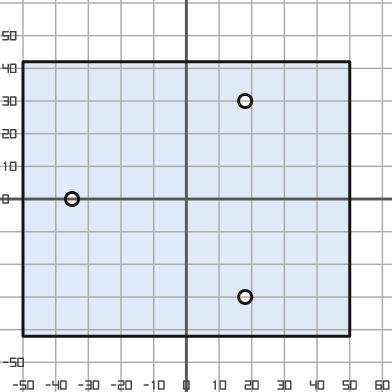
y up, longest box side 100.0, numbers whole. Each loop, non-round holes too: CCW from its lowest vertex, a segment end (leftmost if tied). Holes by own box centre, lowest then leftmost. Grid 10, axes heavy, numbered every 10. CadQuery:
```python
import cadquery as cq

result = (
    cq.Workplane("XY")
    .moveTo(-50.0, -42.0)
    .lineTo(50.0, -42.0)
    .lineTo(50.0, 42.0)
    .lineTo(-50.0, 42.0)
    .close()
    .moveTo(18.0, -30.0)
    .circle(2.0)
    .moveTo(-35.0, 0.0)
    .circle(2.0)
    .moveTo(18.0, 30.0)
    .circle(2.0)
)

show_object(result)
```